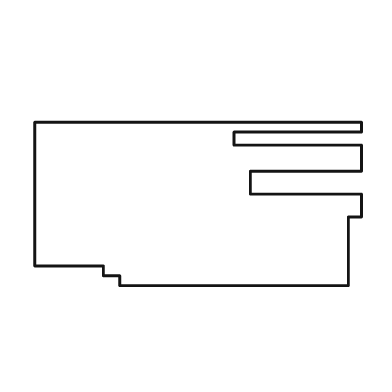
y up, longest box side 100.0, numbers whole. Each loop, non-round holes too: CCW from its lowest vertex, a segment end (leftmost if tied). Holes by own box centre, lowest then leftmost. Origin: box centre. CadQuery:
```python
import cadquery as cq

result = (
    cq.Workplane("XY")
    .moveTo(-24.0, -25.0)
    .lineTo(46.0, -25.0)
    .lineTo(46.0, -4.0)
    .lineTo(50.0, -4.0)
    .lineTo(50.0, 3.0)
    .lineTo(16.0, 3.0)
    .lineTo(16.0, 10.0)
    .lineTo(50.0, 10.0)
    .lineTo(50.0, 18.0)
    .lineTo(11.0, 18.0)
    .lineTo(11.0, 22.0)
    .lineTo(50.0, 22.0)
    .lineTo(50.0, 25.0)
    .lineTo(-50.0, 25.0)
    .lineTo(-50.0, -19.0)
    .lineTo(-29.0, -19.0)
    .lineTo(-29.0, -22.0)
    .lineTo(-24.0, -22.0)
    .close()
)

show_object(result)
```